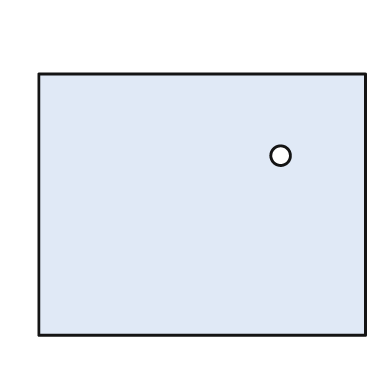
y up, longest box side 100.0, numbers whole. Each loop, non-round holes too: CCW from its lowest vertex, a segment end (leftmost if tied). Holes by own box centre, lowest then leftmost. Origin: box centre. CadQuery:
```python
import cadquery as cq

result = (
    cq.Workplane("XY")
    .moveTo(-50.0, -40.0)
    .lineTo(50.0, -40.0)
    .lineTo(50.0, 40.0)
    .lineTo(-50.0, 40.0)
    .close()
    .moveTo(24.0, 15.0)
    .circle(3.0)
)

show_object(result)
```